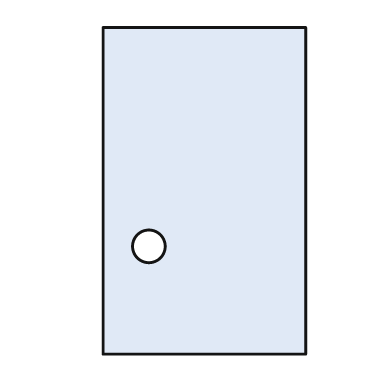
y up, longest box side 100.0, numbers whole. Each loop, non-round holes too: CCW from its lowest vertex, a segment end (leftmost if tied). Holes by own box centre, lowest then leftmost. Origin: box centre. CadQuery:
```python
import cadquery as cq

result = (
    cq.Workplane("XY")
    .moveTo(-31.0, -50.0)
    .lineTo(31.0, -50.0)
    .lineTo(31.0, 50.0)
    .lineTo(-31.0, 50.0)
    .close()
    .moveTo(-17.0, -17.0)
    .circle(5.0)
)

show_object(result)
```